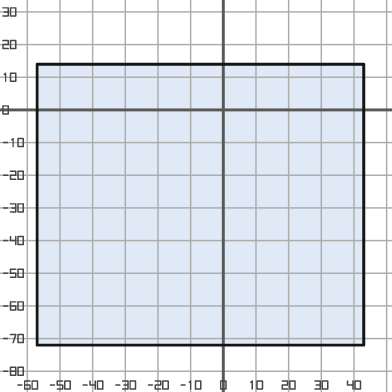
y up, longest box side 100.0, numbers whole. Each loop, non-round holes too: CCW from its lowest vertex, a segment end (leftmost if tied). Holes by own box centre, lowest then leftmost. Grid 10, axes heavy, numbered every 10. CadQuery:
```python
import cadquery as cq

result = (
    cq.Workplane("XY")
    .moveTo(-57.0, -72.0)
    .lineTo(43.0, -72.0)
    .lineTo(43.0, 14.0)
    .lineTo(-57.0, 14.0)
    .close()
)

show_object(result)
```